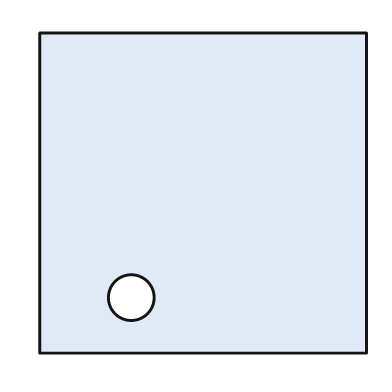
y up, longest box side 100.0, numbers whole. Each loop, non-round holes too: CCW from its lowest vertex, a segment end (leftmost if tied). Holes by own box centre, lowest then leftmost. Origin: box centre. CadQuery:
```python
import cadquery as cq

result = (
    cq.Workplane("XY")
    .moveTo(-50.0, -49.0)
    .lineTo(50.0, -49.0)
    .lineTo(50.0, 49.0)
    .lineTo(-50.0, 49.0)
    .close()
    .moveTo(-22.0, -32.0)
    .circle(7.0)
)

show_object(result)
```